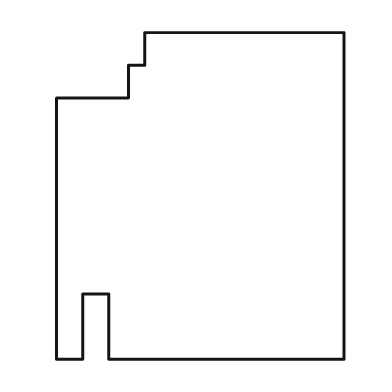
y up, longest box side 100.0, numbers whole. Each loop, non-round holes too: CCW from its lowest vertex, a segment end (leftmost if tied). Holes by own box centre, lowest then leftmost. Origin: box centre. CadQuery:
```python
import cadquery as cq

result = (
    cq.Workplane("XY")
    .moveTo(-44.0, -50.0)
    .lineTo(-36.0, -50.0)
    .lineTo(-36.0, -30.0)
    .lineTo(-28.0, -30.0)
    .lineTo(-28.0, -50.0)
    .lineTo(44.0, -50.0)
    .lineTo(44.0, 50.0)
    .lineTo(-17.0, 50.0)
    .lineTo(-17.0, 40.0)
    .lineTo(-22.0, 40.0)
    .lineTo(-22.0, 30.0)
    .lineTo(-44.0, 30.0)
    .close()
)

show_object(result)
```